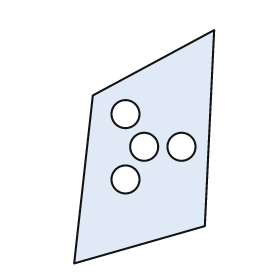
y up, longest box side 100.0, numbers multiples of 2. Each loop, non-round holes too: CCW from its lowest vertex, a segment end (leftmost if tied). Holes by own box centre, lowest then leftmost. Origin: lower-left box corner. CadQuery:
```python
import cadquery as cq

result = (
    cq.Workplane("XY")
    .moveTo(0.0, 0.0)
    .lineTo(56.0, 16.0)
    .lineTo(60.0, 100.0)
    .lineTo(8.0, 72.0)
    .close()
    .moveTo(22.0, 36.0)
    .circle(6.0)
    .moveTo(30.0, 50.0)
    .circle(6.0)
    .moveTo(46.0, 50.0)
    .circle(6.0)
    .moveTo(22.0, 64.0)
    .circle(6.0)
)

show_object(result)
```